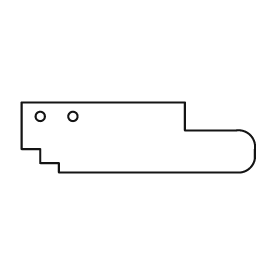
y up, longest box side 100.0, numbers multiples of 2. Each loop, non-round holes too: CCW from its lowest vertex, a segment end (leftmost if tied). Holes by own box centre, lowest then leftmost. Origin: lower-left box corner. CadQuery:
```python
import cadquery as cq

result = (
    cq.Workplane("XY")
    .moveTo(16.0, 0.0)
    .lineTo(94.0, 0.0)
    .threePointArc((98.0, 2.0), (100.0, 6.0))
    .lineTo(100.0, 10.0)
    .threePointArc((98.0, 16.0), (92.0, 18.0))
    .lineTo(70.0, 18.0)
    .lineTo(70.0, 30.0)
    .lineTo(0.0, 30.0)
    .lineTo(0.0, 10.0)
    .lineTo(8.0, 10.0)
    .lineTo(8.0, 4.0)
    .lineTo(16.0, 4.0)
    .close()
    .moveTo(8.0, 24.0)
    .circle(2.0)
    .moveTo(22.0, 24.0)
    .circle(2.0)
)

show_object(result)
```